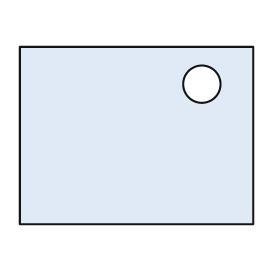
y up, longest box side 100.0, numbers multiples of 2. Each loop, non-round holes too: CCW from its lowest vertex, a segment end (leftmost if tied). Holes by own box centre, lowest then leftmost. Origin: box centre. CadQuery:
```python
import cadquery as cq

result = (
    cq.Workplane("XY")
    .moveTo(-50.0, -38.0)
    .lineTo(50.0, -38.0)
    .lineTo(50.0, 38.0)
    .lineTo(-50.0, 38.0)
    .close()
    .moveTo(28.0, 22.0)
    .circle(8.0)
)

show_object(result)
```